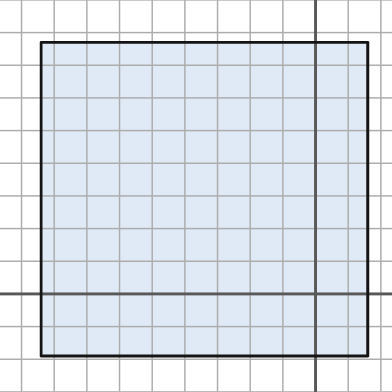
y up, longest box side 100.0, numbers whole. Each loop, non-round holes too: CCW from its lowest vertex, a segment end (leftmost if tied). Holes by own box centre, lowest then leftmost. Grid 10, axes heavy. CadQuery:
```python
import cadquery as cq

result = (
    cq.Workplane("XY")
    .moveTo(-84.0, -19.0)
    .lineTo(16.0, -19.0)
    .lineTo(16.0, 77.0)
    .lineTo(-84.0, 77.0)
    .close()
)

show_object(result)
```